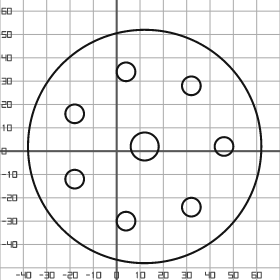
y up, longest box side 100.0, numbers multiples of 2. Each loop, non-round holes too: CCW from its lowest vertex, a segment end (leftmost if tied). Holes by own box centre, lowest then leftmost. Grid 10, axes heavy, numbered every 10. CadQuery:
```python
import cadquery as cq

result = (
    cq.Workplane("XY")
    .moveTo(12.0, 2.0)
    .circle(50.0)
    .moveTo(4.0, -30.0)
    .circle(4.0)
    .moveTo(32.0, -24.0)
    .circle(4.0)
    .moveTo(-18.0, -12.0)
    .circle(4.0)
    .moveTo(12.0, 2.0)
    .circle(6.0)
    .moveTo(46.0, 2.0)
    .circle(4.0)
    .moveTo(-18.0, 16.0)
    .circle(4.0)
    .moveTo(32.0, 28.0)
    .circle(4.0)
    .moveTo(4.0, 34.0)
    .circle(4.0)
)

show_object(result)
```